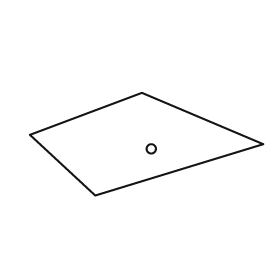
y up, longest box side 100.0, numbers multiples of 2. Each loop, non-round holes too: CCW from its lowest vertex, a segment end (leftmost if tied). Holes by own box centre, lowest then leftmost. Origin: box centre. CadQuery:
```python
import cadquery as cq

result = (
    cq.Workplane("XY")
    .moveTo(-22.0, -22.0)
    .lineTo(50.0, 0.0)
    .lineTo(-2.0, 22.0)
    .lineTo(-50.0, 4.0)
    .close()
    .moveTo(2.0, -2.0)
    .circle(2.0)
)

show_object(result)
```